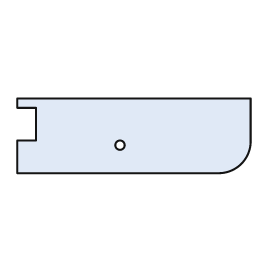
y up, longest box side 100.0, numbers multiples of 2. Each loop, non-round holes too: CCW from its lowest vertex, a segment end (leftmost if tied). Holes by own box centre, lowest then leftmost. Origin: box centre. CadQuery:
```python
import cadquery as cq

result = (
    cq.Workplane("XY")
    .moveTo(-50.0, -16.0)
    .lineTo(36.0, -16.0)
    .threePointArc((46.0, -12.0), (50.0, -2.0))
    .lineTo(50.0, 16.0)
    .lineTo(-50.0, 16.0)
    .lineTo(-50.0, 12.0)
    .lineTo(-42.0, 12.0)
    .lineTo(-42.0, -2.0)
    .lineTo(-50.0, -2.0)
    .close()
    .moveTo(-6.0, -4.0)
    .circle(2.0)
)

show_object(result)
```